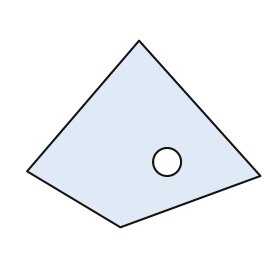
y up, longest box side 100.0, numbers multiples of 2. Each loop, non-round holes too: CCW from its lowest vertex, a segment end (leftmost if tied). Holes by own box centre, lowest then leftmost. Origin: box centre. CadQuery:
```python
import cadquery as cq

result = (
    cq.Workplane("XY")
    .moveTo(-10.0, -40.0)
    .lineTo(50.0, -18.0)
    .lineTo(-2.0, 40.0)
    .lineTo(-50.0, -16.0)
    .close()
    .moveTo(10.0, -12.0)
    .circle(6.0)
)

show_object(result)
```